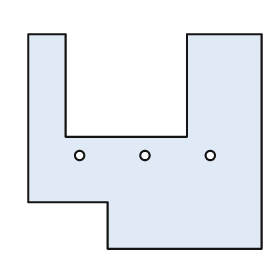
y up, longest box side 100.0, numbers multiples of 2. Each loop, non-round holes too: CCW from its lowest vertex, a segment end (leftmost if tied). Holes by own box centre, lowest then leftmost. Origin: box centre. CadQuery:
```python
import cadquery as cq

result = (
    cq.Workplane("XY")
    .moveTo(-16.0, -46.0)
    .lineTo(50.0, -46.0)
    .lineTo(50.0, 46.0)
    .lineTo(18.0, 46.0)
    .lineTo(18.0, 2.0)
    .lineTo(-34.0, 2.0)
    .lineTo(-34.0, 46.0)
    .lineTo(-50.0, 46.0)
    .lineTo(-50.0, -26.0)
    .lineTo(-16.0, -26.0)
    .close()
    .moveTo(-28.0, -6.0)
    .circle(2.0)
    .moveTo(0.0, -6.0)
    .circle(2.0)
    .moveTo(28.0, -6.0)
    .circle(2.0)
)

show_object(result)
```